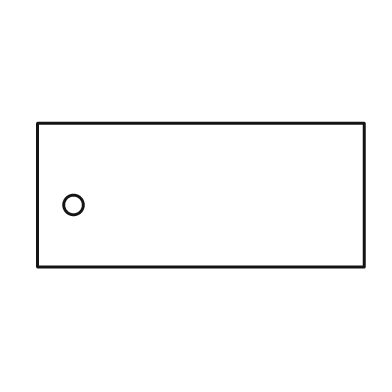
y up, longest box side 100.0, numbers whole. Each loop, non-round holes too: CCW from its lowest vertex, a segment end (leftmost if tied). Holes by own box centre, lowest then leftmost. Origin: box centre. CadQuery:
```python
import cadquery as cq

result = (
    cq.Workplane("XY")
    .moveTo(-50.0, -22.0)
    .lineTo(50.0, -22.0)
    .lineTo(50.0, 22.0)
    .lineTo(-50.0, 22.0)
    .close()
    .moveTo(-39.0, -3.0)
    .circle(3.0)
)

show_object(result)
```